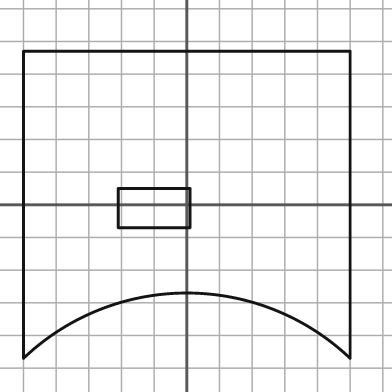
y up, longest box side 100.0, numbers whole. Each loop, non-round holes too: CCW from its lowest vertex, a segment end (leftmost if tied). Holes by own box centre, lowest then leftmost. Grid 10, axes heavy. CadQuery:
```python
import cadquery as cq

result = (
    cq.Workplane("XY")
    .moveTo(-50.0, -47.0)
    .threePointArc((0.0, -27.0), (50.0, -47.0))
    .lineTo(50.0, 47.0)
    .lineTo(-50.0, 47.0)
    .close()
    .moveTo(-21.0, -7.0)
    .lineTo(1.0, -7.0)
    .lineTo(1.0, 5.0)
    .lineTo(-21.0, 5.0)
    .close()
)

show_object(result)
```